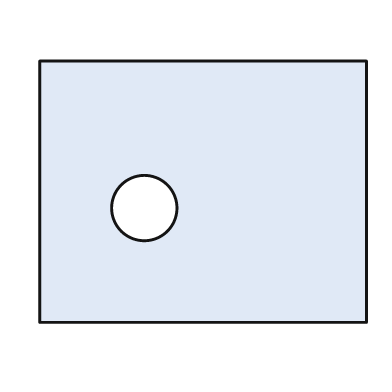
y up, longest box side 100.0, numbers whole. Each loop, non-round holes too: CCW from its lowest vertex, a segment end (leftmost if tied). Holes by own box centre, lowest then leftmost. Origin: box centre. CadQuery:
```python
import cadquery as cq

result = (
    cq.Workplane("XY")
    .moveTo(-50.0, -40.0)
    .lineTo(50.0, -40.0)
    .lineTo(50.0, 40.0)
    .lineTo(-50.0, 40.0)
    .close()
    .moveTo(-18.0, -5.0)
    .circle(10.0)
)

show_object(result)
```